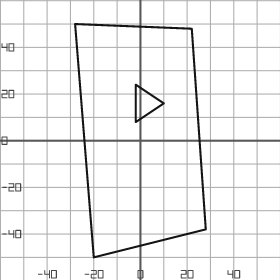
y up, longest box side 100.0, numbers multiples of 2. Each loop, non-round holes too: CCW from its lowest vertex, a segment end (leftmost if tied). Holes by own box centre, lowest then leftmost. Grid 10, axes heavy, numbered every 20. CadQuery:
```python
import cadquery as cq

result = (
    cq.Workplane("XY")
    .moveTo(-20.0, -50.0)
    .lineTo(28.0, -38.0)
    .lineTo(22.0, 48.0)
    .lineTo(-28.0, 50.0)
    .close()
    .moveTo(-2.0, 8.0)
    .lineTo(10.0, 16.0)
    .lineTo(-2.0, 24.0)
    .close()
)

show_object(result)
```